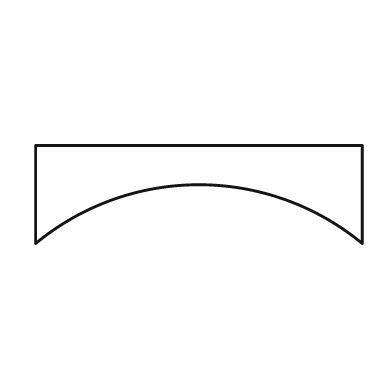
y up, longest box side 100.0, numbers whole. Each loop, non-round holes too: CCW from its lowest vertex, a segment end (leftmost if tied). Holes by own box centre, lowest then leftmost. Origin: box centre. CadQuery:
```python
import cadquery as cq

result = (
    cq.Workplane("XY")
    .moveTo(-50.0, -15.0)
    .threePointArc((0.0, 3.0), (50.0, -15.0))
    .lineTo(50.0, 15.0)
    .lineTo(-50.0, 15.0)
    .close()
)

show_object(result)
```